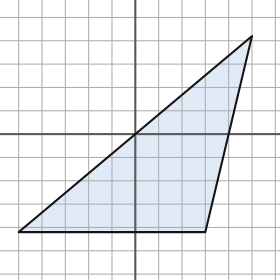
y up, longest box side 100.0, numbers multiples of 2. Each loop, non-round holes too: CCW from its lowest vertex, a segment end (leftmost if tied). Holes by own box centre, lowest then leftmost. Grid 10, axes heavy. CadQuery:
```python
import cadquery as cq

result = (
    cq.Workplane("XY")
    .moveTo(-50.0, -42.0)
    .lineTo(30.0, -42.0)
    .lineTo(50.0, 42.0)
    .close()
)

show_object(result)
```